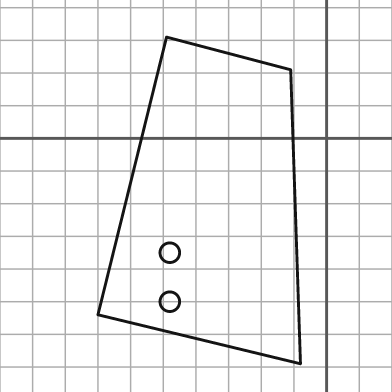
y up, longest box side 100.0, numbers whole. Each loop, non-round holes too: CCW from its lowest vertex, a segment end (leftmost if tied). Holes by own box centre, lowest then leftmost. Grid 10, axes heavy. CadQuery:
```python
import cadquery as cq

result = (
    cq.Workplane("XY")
    .moveTo(-8.0, -69.0)
    .lineTo(-11.0, 21.0)
    .lineTo(-49.0, 31.0)
    .lineTo(-70.0, -54.0)
    .close()
    .moveTo(-48.0, -50.0)
    .circle(3.0)
    .moveTo(-48.0, -35.0)
    .circle(3.0)
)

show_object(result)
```